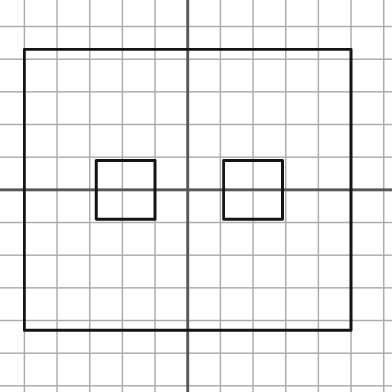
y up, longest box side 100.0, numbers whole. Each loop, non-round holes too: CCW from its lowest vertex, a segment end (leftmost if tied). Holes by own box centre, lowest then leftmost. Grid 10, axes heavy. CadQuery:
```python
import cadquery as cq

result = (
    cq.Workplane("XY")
    .moveTo(-50.0, -43.0)
    .lineTo(50.0, -43.0)
    .lineTo(50.0, 43.0)
    .lineTo(-50.0, 43.0)
    .close()
    .moveTo(-28.0, -9.0)
    .lineTo(-10.0, -9.0)
    .lineTo(-10.0, 9.0)
    .lineTo(-28.0, 9.0)
    .close()
    .moveTo(11.0, -9.0)
    .lineTo(29.0, -9.0)
    .lineTo(29.0, 9.0)
    .lineTo(11.0, 9.0)
    .close()
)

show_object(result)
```